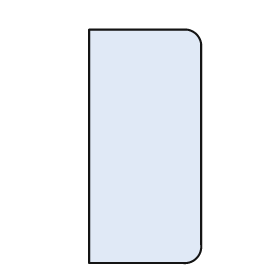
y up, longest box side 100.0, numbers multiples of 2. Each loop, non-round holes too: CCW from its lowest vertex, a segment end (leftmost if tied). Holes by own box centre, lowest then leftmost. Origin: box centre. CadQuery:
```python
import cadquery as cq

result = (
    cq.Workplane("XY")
    .moveTo(-24.0, -50.0)
    .lineTo(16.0, -50.0)
    .threePointArc((22.0, -48.0), (24.0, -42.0))
    .lineTo(24.0, 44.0)
    .threePointArc((22.0, 48.0), (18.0, 50.0))
    .lineTo(-24.0, 50.0)
    .close()
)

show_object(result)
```